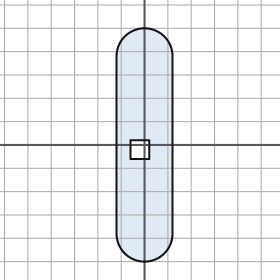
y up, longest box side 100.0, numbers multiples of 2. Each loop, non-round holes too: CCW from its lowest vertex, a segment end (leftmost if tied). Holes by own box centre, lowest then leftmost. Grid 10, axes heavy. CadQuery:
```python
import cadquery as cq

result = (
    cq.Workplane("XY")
    .moveTo(-12.0, -38.0)
    .threePointArc((0.0, -50.0), (12.0, -38.0))
    .lineTo(12.0, 38.0)
    .threePointArc((0.0, 50.0), (-12.0, 38.0))
    .close()
    .moveTo(-6.0, -6.0)
    .lineTo(2.0, -6.0)
    .lineTo(2.0, 2.0)
    .lineTo(-6.0, 2.0)
    .close()
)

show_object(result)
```